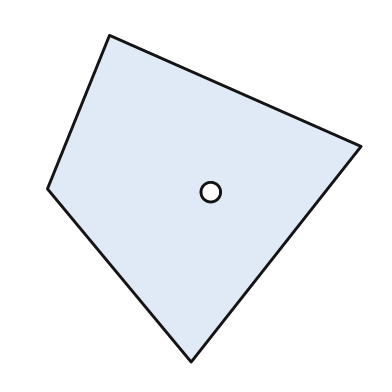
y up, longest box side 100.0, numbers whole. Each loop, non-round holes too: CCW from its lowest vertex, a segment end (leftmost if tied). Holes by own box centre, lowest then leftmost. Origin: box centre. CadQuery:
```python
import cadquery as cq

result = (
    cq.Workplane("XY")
    .moveTo(-4.0, -50.0)
    .lineTo(48.0, 16.0)
    .lineTo(-29.0, 50.0)
    .lineTo(-48.0, 3.0)
    .close()
    .moveTo(2.0, 2.0)
    .circle(3.0)
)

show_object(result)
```